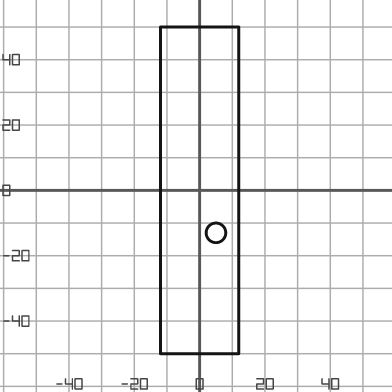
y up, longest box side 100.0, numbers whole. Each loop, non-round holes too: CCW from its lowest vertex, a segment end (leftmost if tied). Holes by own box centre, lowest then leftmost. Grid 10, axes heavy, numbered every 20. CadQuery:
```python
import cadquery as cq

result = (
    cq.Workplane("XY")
    .moveTo(-12.0, -50.0)
    .lineTo(12.0, -50.0)
    .lineTo(12.0, 50.0)
    .lineTo(-12.0, 50.0)
    .close()
    .moveTo(5.0, -13.0)
    .circle(3.0)
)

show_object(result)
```